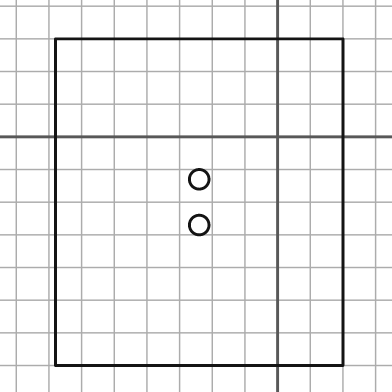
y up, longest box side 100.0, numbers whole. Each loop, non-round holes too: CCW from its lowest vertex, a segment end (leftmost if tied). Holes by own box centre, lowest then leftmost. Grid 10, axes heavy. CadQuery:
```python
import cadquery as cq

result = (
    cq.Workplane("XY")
    .moveTo(-68.0, -70.0)
    .lineTo(20.0, -70.0)
    .lineTo(20.0, 30.0)
    .lineTo(-68.0, 30.0)
    .close()
    .moveTo(-24.0, -27.0)
    .circle(3.0)
    .moveTo(-24.0, -13.0)
    .circle(3.0)
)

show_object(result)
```